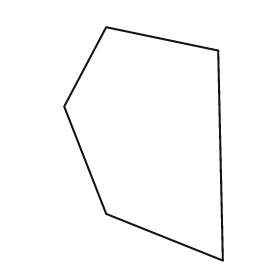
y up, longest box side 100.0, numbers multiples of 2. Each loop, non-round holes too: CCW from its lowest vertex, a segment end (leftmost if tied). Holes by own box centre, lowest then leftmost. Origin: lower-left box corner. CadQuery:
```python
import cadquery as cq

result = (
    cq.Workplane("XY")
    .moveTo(68.0, 0.0)
    .lineTo(66.0, 90.0)
    .lineTo(18.0, 100.0)
    .lineTo(0.0, 66.0)
    .lineTo(18.0, 20.0)
    .close()
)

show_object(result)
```